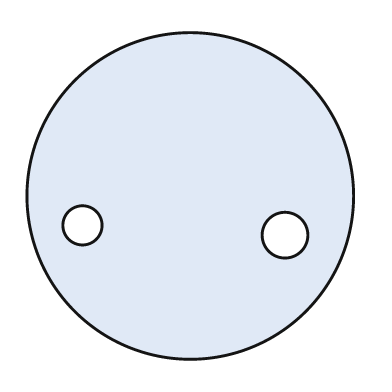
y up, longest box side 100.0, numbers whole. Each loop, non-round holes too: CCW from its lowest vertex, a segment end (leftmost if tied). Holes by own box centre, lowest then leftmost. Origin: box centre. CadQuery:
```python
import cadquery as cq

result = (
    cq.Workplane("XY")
    .moveTo(0.0, 0.0)
    .circle(50.0)
    .moveTo(29.0, -12.0)
    .circle(7.0)
    .moveTo(-33.0, -9.0)
    .circle(6.0)
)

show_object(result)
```